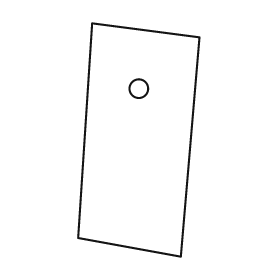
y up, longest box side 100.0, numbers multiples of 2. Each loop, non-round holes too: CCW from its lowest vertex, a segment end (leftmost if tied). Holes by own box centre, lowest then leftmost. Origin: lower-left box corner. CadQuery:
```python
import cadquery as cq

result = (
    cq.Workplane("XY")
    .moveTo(44.0, 0.0)
    .lineTo(52.0, 94.0)
    .lineTo(6.0, 100.0)
    .lineTo(0.0, 8.0)
    .close()
    .moveTo(26.0, 72.0)
    .circle(4.0)
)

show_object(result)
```